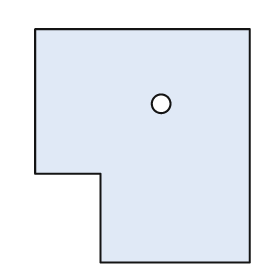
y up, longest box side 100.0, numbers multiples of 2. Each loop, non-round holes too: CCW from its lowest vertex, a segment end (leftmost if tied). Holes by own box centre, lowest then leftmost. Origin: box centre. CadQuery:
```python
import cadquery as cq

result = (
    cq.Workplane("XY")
    .moveTo(-18.0, -50.0)
    .lineTo(46.0, -50.0)
    .lineTo(46.0, 50.0)
    .lineTo(-46.0, 50.0)
    .lineTo(-46.0, -12.0)
    .lineTo(-18.0, -12.0)
    .close()
    .moveTo(8.0, 18.0)
    .circle(4.0)
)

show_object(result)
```